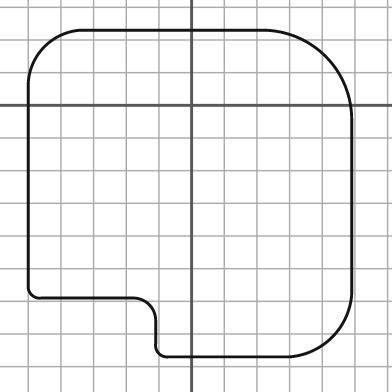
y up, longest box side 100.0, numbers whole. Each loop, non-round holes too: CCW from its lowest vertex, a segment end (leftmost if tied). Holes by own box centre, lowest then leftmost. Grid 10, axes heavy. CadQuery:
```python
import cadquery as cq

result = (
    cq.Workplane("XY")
    .moveTo(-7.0, -77.0)
    .lineTo(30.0, -77.0)
    .threePointArc((43.0, -71.0), (49.0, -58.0))
    .lineTo(49.0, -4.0)
    .threePointArc((41.0, 15.0), (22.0, 23.0))
    .lineTo(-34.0, 23.0)
    .threePointArc((-45.0, 18.0), (-50.0, 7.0))
    .lineTo(-50.0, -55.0)
    .threePointArc((-49.0, -58.0), (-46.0, -59.0))
    .lineTo(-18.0, -59.0)
    .threePointArc((-13.0, -61.0), (-11.0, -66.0))
    .lineTo(-11.0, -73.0)
    .threePointArc((-10.0, -76.0), (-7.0, -77.0))
    .close()
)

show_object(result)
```